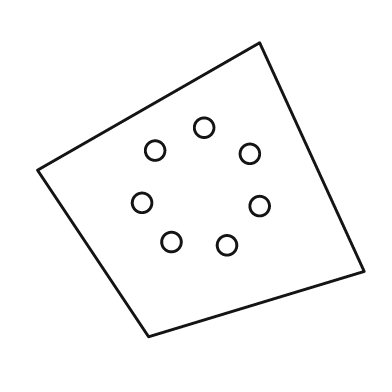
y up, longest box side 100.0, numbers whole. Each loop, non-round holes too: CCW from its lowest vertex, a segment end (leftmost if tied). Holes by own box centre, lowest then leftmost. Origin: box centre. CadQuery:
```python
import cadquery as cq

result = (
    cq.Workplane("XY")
    .moveTo(-16.0, -45.0)
    .lineTo(50.0, -25.0)
    .lineTo(18.0, 45.0)
    .lineTo(-50.0, 6.0)
    .close()
    .moveTo(8.0, -17.0)
    .circle(3.0)
    .moveTo(-9.0, -16.0)
    .circle(3.0)
    .moveTo(18.0, -5.0)
    .circle(3.0)
    .moveTo(-18.0, -4.0)
    .circle(3.0)
    .moveTo(15.0, 11.0)
    .circle(3.0)
    .moveTo(-14.0, 12.0)
    .circle(3.0)
    .moveTo(1.0, 19.0)
    .circle(3.0)
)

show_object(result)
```